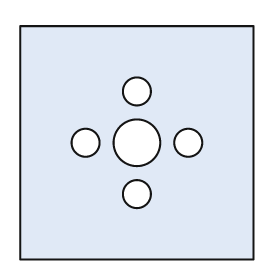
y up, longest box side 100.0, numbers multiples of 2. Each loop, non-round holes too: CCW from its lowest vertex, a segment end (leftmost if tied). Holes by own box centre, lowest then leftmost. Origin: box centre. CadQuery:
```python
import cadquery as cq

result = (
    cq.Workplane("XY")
    .moveTo(-50.0, -50.0)
    .lineTo(50.0, -50.0)
    .lineTo(50.0, 50.0)
    .lineTo(-50.0, 50.0)
    .close()
    .moveTo(0.0, -22.0)
    .circle(6.0)
    .moveTo(-22.0, 0.0)
    .circle(6.0)
    .moveTo(0.0, 0.0)
    .circle(10.0)
    .moveTo(22.0, 0.0)
    .circle(6.0)
    .moveTo(0.0, 22.0)
    .circle(6.0)
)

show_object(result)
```